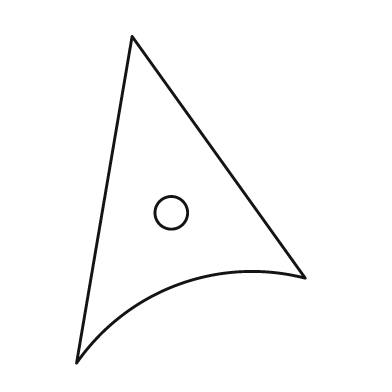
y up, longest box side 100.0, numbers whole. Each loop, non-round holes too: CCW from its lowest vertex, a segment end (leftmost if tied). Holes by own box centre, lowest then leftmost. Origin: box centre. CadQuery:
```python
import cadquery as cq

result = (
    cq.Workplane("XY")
    .moveTo(-35.0, -50.0)
    .threePointArc((-4.0, -26.0), (35.0, -24.0))
    .lineTo(-18.0, 50.0)
    .close()
    .moveTo(-6.0, -4.0)
    .circle(5.0)
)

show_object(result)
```